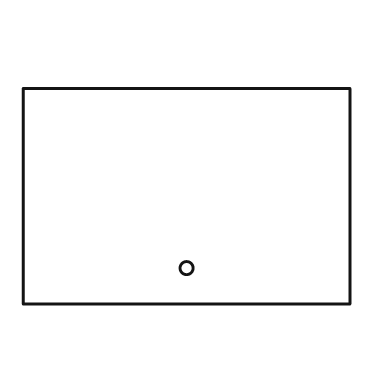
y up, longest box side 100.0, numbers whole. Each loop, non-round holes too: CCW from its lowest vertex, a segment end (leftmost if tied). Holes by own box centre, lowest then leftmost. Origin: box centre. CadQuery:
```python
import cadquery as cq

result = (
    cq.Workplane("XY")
    .moveTo(-50.0, -33.0)
    .lineTo(50.0, -33.0)
    .lineTo(50.0, 33.0)
    .lineTo(-50.0, 33.0)
    .close()
    .moveTo(0.0, -22.0)
    .circle(2.0)
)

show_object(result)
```